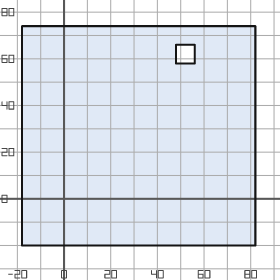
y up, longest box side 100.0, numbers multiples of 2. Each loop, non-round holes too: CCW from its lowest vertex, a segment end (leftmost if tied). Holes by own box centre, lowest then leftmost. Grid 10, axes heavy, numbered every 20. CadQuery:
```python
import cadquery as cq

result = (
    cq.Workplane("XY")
    .moveTo(-18.0, -20.0)
    .lineTo(82.0, -20.0)
    .lineTo(82.0, 74.0)
    .lineTo(-18.0, 74.0)
    .close()
    .moveTo(48.0, 58.0)
    .lineTo(56.0, 58.0)
    .lineTo(56.0, 66.0)
    .lineTo(48.0, 66.0)
    .close()
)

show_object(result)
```